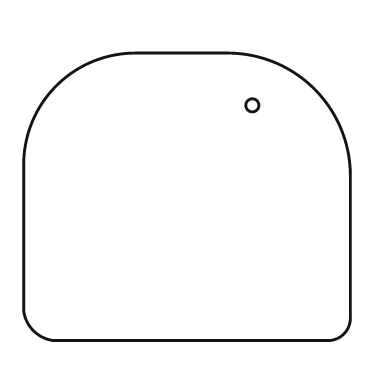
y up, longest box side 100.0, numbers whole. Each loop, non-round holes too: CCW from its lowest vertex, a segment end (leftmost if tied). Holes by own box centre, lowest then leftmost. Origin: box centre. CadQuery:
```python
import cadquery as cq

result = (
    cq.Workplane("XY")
    .moveTo(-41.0, -44.0)
    .lineTo(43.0, -44.0)
    .threePointArc((48.0, -42.0), (50.0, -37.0))
    .lineTo(50.0, 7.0)
    .threePointArc((39.0, 33.0), (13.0, 44.0))
    .lineTo(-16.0, 44.0)
    .threePointArc((-40.0, 34.0), (-50.0, 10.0))
    .lineTo(-50.0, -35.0)
    .threePointArc((-47.0, -41.0), (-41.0, -44.0))
    .close()
    .moveTo(20.0, 28.0)
    .circle(2.0)
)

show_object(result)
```